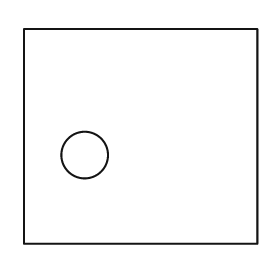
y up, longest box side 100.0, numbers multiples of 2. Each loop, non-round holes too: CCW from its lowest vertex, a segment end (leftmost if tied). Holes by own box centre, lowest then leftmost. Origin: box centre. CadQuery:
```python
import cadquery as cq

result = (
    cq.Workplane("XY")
    .moveTo(-50.0, -46.0)
    .lineTo(50.0, -46.0)
    .lineTo(50.0, 46.0)
    .lineTo(-50.0, 46.0)
    .close()
    .moveTo(-24.0, -8.0)
    .circle(10.0)
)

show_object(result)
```